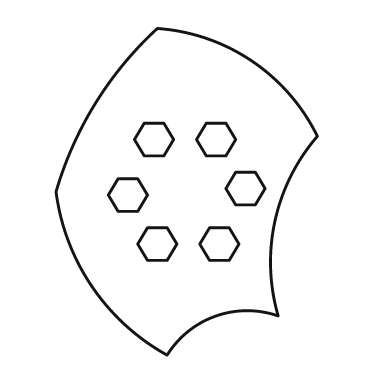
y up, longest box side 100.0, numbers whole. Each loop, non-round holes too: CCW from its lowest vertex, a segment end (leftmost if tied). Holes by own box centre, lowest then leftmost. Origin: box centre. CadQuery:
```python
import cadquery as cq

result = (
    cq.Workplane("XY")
    .moveTo(-6.0, -50.0)
    .threePointArc((9.0, -38.0), (28.0, -38.0))
    .threePointArc((27.0, -9.0), (40.0, 17.0))
    .threePointArc((20.0, 40.0), (-9.0, 50.0))
    .threePointArc((-28.0, 27.0), (-40.0, 0.0))
    .threePointArc((-29.0, -29.0), (-6.0, -50.0))
    .close()
    .moveTo(-12.0, -21.0)
    .lineTo(-6.0, -21.0)
    .lineTo(-3.0, -16.0)
    .lineTo(-6.0, -11.0)
    .lineTo(-12.0, -11.0)
    .lineTo(-15.0, -16.0)
    .close()
    .moveTo(7.0, -21.0)
    .lineTo(13.0, -21.0)
    .lineTo(16.0, -16.0)
    .lineTo(13.0, -11.0)
    .lineTo(7.0, -11.0)
    .lineTo(4.0, -16.0)
    .close()
    .moveTo(-21.0, -6.0)
    .lineTo(-15.0, -6.0)
    .lineTo(-12.0, -1.0)
    .lineTo(-15.0, 4.0)
    .lineTo(-21.0, 4.0)
    .lineTo(-24.0, -1.0)
    .close()
    .moveTo(15.0, -4.0)
    .lineTo(21.0, -4.0)
    .lineTo(24.0, 1.0)
    .lineTo(21.0, 6.0)
    .lineTo(15.0, 6.0)
    .lineTo(12.0, 1.0)
    .close()
    .moveTo(-13.0, 11.0)
    .lineTo(-7.0, 11.0)
    .lineTo(-4.0, 16.0)
    .lineTo(-7.0, 21.0)
    .lineTo(-13.0, 21.0)
    .lineTo(-16.0, 16.0)
    .close()
    .moveTo(6.0, 11.0)
    .lineTo(12.0, 11.0)
    .lineTo(15.0, 16.0)
    .lineTo(12.0, 21.0)
    .lineTo(6.0, 21.0)
    .lineTo(3.0, 16.0)
    .close()
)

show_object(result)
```